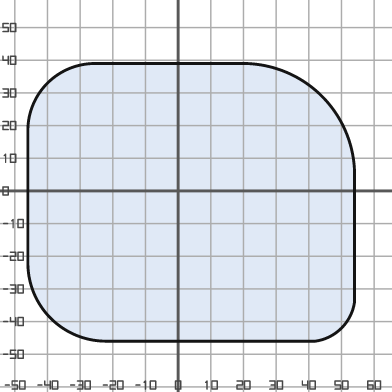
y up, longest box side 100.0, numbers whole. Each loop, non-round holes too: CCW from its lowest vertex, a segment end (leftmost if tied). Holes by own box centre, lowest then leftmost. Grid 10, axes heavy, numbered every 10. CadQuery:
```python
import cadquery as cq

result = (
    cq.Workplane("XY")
    .moveTo(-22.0, -46.0)
    .lineTo(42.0, -46.0)
    .threePointArc((50.0, -42.0), (54.0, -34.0))
    .lineTo(54.0, 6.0)
    .threePointArc((44.0, 29.0), (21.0, 39.0))
    .lineTo(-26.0, 39.0)
    .threePointArc((-40.0, 33.0), (-46.0, 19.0))
    .lineTo(-46.0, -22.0)
    .threePointArc((-39.0, -39.0), (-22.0, -46.0))
    .close()
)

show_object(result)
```